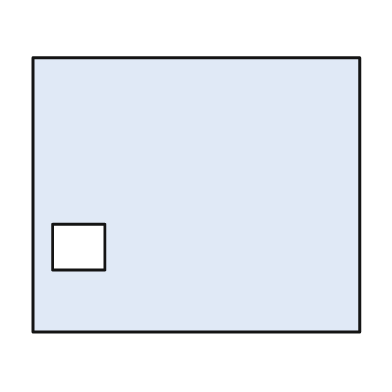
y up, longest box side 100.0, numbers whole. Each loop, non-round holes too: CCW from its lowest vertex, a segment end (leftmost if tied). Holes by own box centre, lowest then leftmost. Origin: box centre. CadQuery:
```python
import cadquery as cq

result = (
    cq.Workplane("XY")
    .moveTo(-50.0, -42.0)
    .lineTo(50.0, -42.0)
    .lineTo(50.0, 42.0)
    .lineTo(-50.0, 42.0)
    .close()
    .moveTo(-44.0, -23.0)
    .lineTo(-28.0, -23.0)
    .lineTo(-28.0, -9.0)
    .lineTo(-44.0, -9.0)
    .close()
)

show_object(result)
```